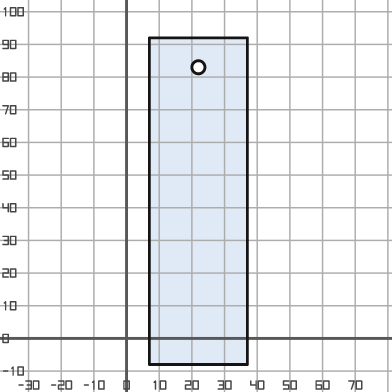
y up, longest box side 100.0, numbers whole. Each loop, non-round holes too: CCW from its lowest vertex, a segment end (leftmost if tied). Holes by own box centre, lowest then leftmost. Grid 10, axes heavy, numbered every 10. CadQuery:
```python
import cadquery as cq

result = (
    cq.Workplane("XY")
    .moveTo(7.0, -8.0)
    .lineTo(37.0, -8.0)
    .lineTo(37.0, 92.0)
    .lineTo(7.0, 92.0)
    .close()
    .moveTo(22.0, 83.0)
    .circle(2.0)
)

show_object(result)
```